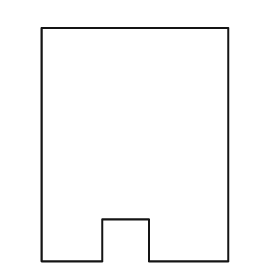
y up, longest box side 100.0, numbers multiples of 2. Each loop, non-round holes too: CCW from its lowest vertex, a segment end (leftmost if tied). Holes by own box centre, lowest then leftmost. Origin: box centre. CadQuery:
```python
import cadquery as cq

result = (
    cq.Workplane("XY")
    .moveTo(-40.0, -50.0)
    .lineTo(-14.0, -50.0)
    .lineTo(-14.0, -32.0)
    .lineTo(6.0, -32.0)
    .lineTo(6.0, -50.0)
    .lineTo(40.0, -50.0)
    .lineTo(40.0, 50.0)
    .lineTo(-40.0, 50.0)
    .close()
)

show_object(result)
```